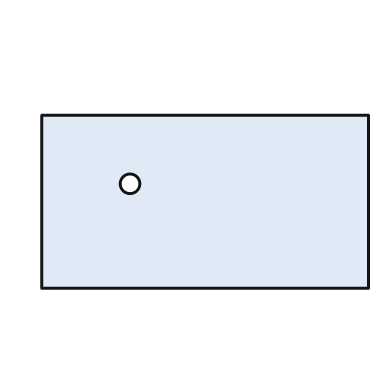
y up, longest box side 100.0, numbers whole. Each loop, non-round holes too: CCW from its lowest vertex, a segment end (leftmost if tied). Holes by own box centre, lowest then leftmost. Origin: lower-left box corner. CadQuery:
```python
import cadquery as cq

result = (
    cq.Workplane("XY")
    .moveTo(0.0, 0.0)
    .lineTo(100.0, 0.0)
    .lineTo(100.0, 53.0)
    .lineTo(0.0, 53.0)
    .close()
    .moveTo(27.0, 32.0)
    .circle(3.0)
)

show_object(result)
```